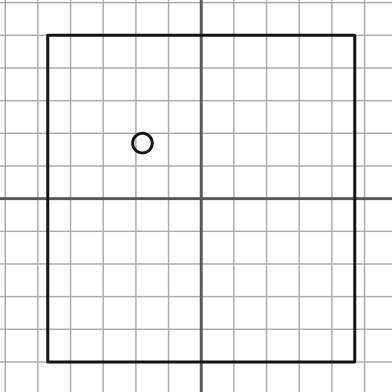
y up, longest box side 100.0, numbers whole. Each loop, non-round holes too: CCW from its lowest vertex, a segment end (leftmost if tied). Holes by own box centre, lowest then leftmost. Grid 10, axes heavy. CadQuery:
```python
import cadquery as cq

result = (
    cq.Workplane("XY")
    .moveTo(-47.0, -50.0)
    .lineTo(47.0, -50.0)
    .lineTo(47.0, 50.0)
    .lineTo(-47.0, 50.0)
    .close()
    .moveTo(-18.0, 17.0)
    .circle(3.0)
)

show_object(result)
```